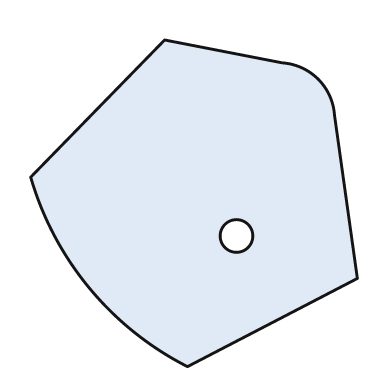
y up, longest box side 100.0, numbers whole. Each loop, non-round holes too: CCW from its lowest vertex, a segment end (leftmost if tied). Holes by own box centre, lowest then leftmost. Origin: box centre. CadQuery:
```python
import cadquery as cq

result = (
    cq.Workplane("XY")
    .moveTo(-2.0, -50.0)
    .lineTo(50.0, -23.0)
    .lineTo(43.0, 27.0)
    .threePointArc((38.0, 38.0), (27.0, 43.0))
    .lineTo(-9.0, 50.0)
    .lineTo(-50.0, 8.0)
    .threePointArc((-32.0, -26.0), (-2.0, -50.0))
    .close()
    .moveTo(13.0, -10.0)
    .circle(5.0)
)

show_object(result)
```